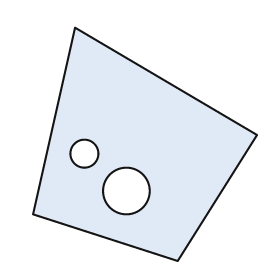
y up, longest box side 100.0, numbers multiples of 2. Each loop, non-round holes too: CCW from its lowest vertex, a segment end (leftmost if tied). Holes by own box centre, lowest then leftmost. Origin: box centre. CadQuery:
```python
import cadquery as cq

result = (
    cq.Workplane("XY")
    .moveTo(14.0, -50.0)
    .lineTo(48.0, 4.0)
    .lineTo(-30.0, 50.0)
    .lineTo(-48.0, -30.0)
    .close()
    .moveTo(-8.0, -20.0)
    .circle(10.0)
    .moveTo(-26.0, -4.0)
    .circle(6.0)
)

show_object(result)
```